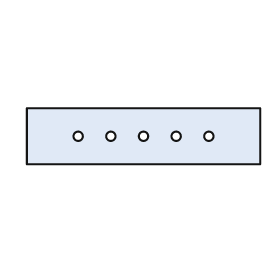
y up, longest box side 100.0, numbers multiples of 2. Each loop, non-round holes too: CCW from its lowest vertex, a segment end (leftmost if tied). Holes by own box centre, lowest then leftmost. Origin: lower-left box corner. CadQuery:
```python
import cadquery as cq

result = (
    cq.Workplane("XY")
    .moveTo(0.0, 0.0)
    .lineTo(100.0, 0.0)
    .lineTo(100.0, 24.0)
    .lineTo(0.0, 24.0)
    .close()
    .moveTo(22.0, 12.0)
    .circle(2.0)
    .moveTo(36.0, 12.0)
    .circle(2.0)
    .moveTo(50.0, 12.0)
    .circle(2.0)
    .moveTo(64.0, 12.0)
    .circle(2.0)
    .moveTo(78.0, 12.0)
    .circle(2.0)
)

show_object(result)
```